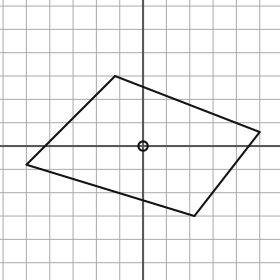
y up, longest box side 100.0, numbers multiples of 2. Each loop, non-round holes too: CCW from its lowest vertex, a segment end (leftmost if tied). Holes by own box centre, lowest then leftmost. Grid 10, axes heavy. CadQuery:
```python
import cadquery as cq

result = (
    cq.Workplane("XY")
    .moveTo(22.0, -30.0)
    .lineTo(50.0, 6.0)
    .lineTo(-12.0, 30.0)
    .lineTo(-50.0, -8.0)
    .close()
    .moveTo(0.0, 0.0)
    .circle(2.0)
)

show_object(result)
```